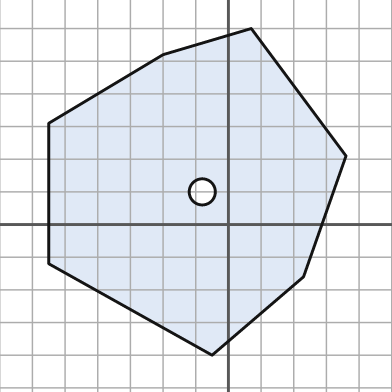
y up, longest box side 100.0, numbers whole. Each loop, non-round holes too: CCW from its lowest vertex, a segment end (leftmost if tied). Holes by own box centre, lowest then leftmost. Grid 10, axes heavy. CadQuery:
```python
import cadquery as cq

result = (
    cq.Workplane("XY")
    .moveTo(-5.0, -40.0)
    .lineTo(23.0, -16.0)
    .lineTo(36.0, 21.0)
    .lineTo(7.0, 60.0)
    .lineTo(-20.0, 52.0)
    .lineTo(-55.0, 31.0)
    .lineTo(-55.0, -12.0)
    .close()
    .moveTo(-8.0, 10.0)
    .circle(4.0)
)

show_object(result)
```